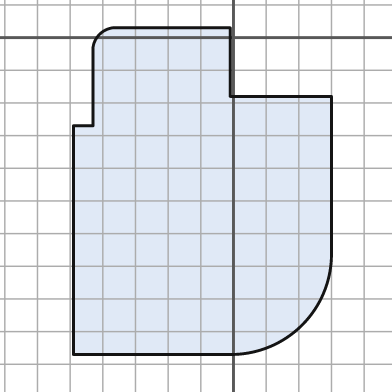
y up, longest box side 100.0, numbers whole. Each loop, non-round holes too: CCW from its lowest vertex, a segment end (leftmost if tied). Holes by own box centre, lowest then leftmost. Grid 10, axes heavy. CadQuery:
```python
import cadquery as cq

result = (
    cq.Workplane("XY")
    .moveTo(-49.0, -97.0)
    .lineTo(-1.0, -97.0)
    .threePointArc((21.0, -88.0), (30.0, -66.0))
    .lineTo(30.0, -18.0)
    .lineTo(-1.0, -18.0)
    .lineTo(-1.0, 3.0)
    .lineTo(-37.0, 3.0)
    .threePointArc((-41.0, 1.0), (-43.0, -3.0))
    .lineTo(-43.0, -27.0)
    .lineTo(-49.0, -27.0)
    .close()
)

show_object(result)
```